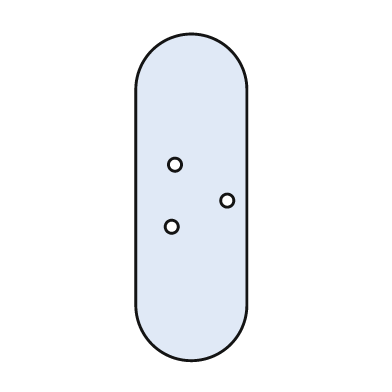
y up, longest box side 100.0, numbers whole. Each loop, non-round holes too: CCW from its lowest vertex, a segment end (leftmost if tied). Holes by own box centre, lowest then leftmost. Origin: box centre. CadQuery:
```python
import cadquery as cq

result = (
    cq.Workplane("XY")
    .moveTo(-17.0, -33.0)
    .threePointArc((0.0, -50.0), (17.0, -33.0))
    .lineTo(17.0, 33.0)
    .threePointArc((0.0, 50.0), (-17.0, 33.0))
    .close()
    .moveTo(-6.0, -9.0)
    .circle(2.0)
    .moveTo(11.0, -1.0)
    .circle(2.0)
    .moveTo(-5.0, 10.0)
    .circle(2.0)
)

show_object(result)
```